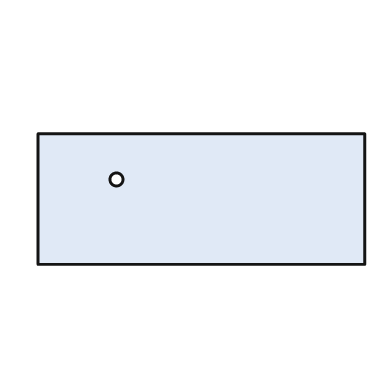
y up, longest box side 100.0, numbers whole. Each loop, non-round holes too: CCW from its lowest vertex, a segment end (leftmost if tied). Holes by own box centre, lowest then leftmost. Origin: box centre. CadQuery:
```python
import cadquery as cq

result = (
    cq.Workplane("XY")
    .moveTo(-50.0, -20.0)
    .lineTo(50.0, -20.0)
    .lineTo(50.0, 20.0)
    .lineTo(-50.0, 20.0)
    .close()
    .moveTo(-26.0, 6.0)
    .circle(2.0)
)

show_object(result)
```